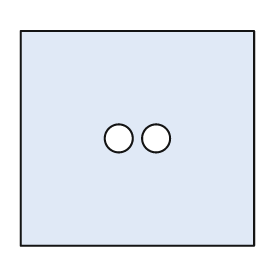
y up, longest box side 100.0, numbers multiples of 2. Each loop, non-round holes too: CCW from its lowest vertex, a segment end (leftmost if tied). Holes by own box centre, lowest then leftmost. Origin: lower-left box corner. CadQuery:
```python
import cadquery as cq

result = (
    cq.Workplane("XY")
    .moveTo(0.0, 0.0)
    .lineTo(100.0, 0.0)
    .lineTo(100.0, 92.0)
    .lineTo(0.0, 92.0)
    .close()
    .moveTo(42.0, 46.0)
    .circle(6.0)
    .moveTo(58.0, 46.0)
    .circle(6.0)
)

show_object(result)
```